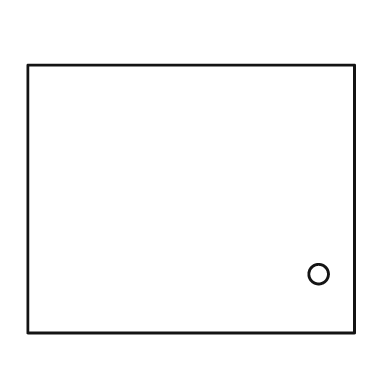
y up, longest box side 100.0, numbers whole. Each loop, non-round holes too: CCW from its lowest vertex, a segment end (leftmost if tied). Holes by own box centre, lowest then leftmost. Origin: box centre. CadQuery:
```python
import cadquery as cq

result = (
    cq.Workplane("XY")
    .moveTo(-50.0, -41.0)
    .lineTo(50.0, -41.0)
    .lineTo(50.0, 41.0)
    .lineTo(-50.0, 41.0)
    .close()
    .moveTo(39.0, -23.0)
    .circle(3.0)
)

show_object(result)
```